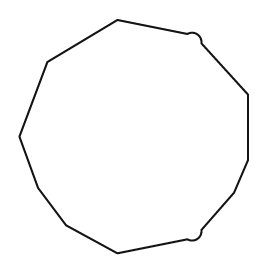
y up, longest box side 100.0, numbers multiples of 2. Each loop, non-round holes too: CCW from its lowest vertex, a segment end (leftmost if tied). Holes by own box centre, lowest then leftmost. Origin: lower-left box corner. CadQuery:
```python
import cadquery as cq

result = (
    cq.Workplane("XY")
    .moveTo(42.0, 0.0)
    .lineTo(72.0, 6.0)
    .threePointArc((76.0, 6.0), (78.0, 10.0))
    .lineTo(92.0, 26.0)
    .lineTo(98.0, 40.0)
    .lineTo(98.0, 68.0)
    .lineTo(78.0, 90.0)
    .threePointArc((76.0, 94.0), (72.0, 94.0))
    .lineTo(42.0, 100.0)
    .lineTo(12.0, 82.0)
    .lineTo(0.0, 50.0)
    .lineTo(8.0, 28.0)
    .lineTo(20.0, 12.0)
    .close()
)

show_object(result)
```